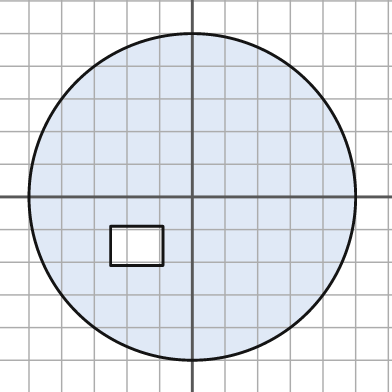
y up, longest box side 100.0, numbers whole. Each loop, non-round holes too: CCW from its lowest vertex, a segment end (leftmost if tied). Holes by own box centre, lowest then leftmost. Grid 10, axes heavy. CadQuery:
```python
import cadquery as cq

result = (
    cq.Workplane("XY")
    .moveTo(0.0, 0.0)
    .circle(50.0)
    .moveTo(-25.0, -21.0)
    .lineTo(-9.0, -21.0)
    .lineTo(-9.0, -9.0)
    .lineTo(-25.0, -9.0)
    .close()
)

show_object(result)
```